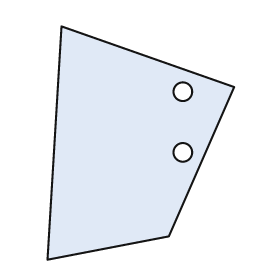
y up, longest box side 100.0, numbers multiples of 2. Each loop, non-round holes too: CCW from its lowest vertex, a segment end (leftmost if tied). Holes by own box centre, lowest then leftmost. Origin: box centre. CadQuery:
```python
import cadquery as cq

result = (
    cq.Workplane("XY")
    .moveTo(-40.0, -50.0)
    .lineTo(12.0, -40.0)
    .lineTo(40.0, 24.0)
    .lineTo(-34.0, 50.0)
    .close()
    .moveTo(18.0, -4.0)
    .circle(4.0)
    .moveTo(18.0, 22.0)
    .circle(4.0)
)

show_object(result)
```